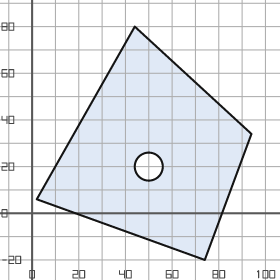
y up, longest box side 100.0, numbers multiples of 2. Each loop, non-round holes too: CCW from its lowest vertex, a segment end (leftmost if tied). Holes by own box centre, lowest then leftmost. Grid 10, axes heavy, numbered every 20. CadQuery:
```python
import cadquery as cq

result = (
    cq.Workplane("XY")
    .moveTo(74.0, -20.0)
    .lineTo(94.0, 34.0)
    .lineTo(44.0, 80.0)
    .lineTo(2.0, 6.0)
    .close()
    .moveTo(50.0, 20.0)
    .circle(6.0)
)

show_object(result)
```